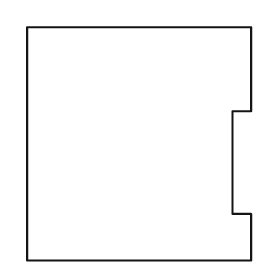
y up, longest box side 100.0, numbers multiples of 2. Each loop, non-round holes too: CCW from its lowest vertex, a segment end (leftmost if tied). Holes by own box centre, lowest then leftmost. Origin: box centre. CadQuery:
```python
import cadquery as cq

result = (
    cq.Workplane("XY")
    .moveTo(-48.0, -50.0)
    .lineTo(48.0, -50.0)
    .lineTo(48.0, -30.0)
    .lineTo(40.0, -30.0)
    .lineTo(40.0, 14.0)
    .lineTo(48.0, 14.0)
    .lineTo(48.0, 50.0)
    .lineTo(-48.0, 50.0)
    .close()
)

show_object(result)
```